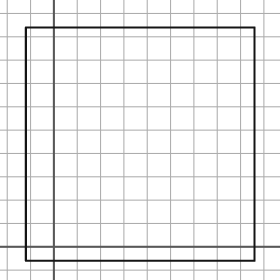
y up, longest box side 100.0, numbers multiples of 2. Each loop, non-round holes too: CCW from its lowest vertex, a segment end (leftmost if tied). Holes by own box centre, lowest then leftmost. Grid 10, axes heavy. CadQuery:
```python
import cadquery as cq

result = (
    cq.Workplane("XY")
    .moveTo(-12.0, -6.0)
    .lineTo(86.0, -6.0)
    .lineTo(86.0, 94.0)
    .lineTo(-12.0, 94.0)
    .close()
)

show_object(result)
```